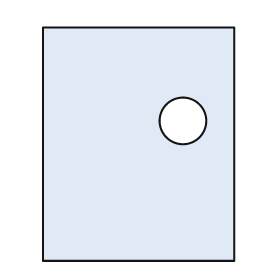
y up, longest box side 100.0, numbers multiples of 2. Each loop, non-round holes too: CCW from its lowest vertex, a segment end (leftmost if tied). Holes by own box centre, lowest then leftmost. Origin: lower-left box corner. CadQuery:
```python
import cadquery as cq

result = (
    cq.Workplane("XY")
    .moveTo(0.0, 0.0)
    .lineTo(82.0, 0.0)
    .lineTo(82.0, 100.0)
    .lineTo(0.0, 100.0)
    .close()
    .moveTo(60.0, 60.0)
    .circle(10.0)
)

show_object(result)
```